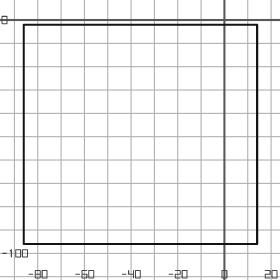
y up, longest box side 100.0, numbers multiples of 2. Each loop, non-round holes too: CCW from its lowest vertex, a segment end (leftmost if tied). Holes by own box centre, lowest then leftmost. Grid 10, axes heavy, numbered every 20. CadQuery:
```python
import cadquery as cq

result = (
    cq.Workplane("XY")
    .moveTo(-86.0, -96.0)
    .lineTo(14.0, -96.0)
    .lineTo(14.0, -2.0)
    .lineTo(-86.0, -2.0)
    .close()
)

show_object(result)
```